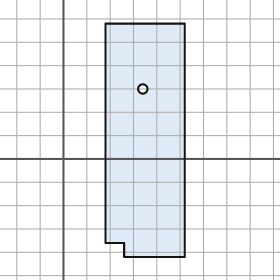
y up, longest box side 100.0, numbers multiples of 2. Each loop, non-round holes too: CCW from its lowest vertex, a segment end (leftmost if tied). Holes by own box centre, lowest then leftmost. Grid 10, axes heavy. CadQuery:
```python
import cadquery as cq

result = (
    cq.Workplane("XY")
    .moveTo(26.0, -42.0)
    .lineTo(52.0, -42.0)
    .lineTo(52.0, 58.0)
    .lineTo(18.0, 58.0)
    .lineTo(18.0, -36.0)
    .lineTo(26.0, -36.0)
    .close()
    .moveTo(34.0, 30.0)
    .circle(2.0)
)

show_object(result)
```